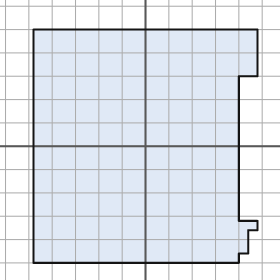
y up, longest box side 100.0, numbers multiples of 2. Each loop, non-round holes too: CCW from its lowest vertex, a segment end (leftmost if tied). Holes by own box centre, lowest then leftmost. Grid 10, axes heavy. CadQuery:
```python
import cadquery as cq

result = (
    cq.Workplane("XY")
    .moveTo(-48.0, -50.0)
    .lineTo(40.0, -50.0)
    .lineTo(40.0, -46.0)
    .lineTo(44.0, -46.0)
    .lineTo(44.0, -36.0)
    .lineTo(48.0, -36.0)
    .lineTo(48.0, -32.0)
    .lineTo(40.0, -32.0)
    .lineTo(40.0, 30.0)
    .lineTo(48.0, 30.0)
    .lineTo(48.0, 50.0)
    .lineTo(-48.0, 50.0)
    .close()
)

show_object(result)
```